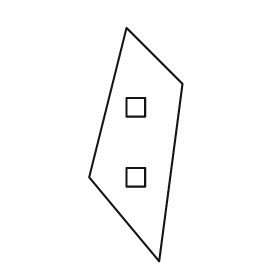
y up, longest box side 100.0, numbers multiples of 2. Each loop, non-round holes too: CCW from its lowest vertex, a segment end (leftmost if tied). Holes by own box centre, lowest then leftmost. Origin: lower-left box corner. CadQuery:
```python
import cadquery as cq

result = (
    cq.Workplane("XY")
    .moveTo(30.0, 0.0)
    .lineTo(40.0, 76.0)
    .lineTo(16.0, 100.0)
    .lineTo(0.0, 36.0)
    .close()
    .moveTo(16.0, 32.0)
    .lineTo(24.0, 32.0)
    .lineTo(24.0, 40.0)
    .lineTo(16.0, 40.0)
    .close()
    .moveTo(16.0, 62.0)
    .lineTo(24.0, 62.0)
    .lineTo(24.0, 70.0)
    .lineTo(16.0, 70.0)
    .close()
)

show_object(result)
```